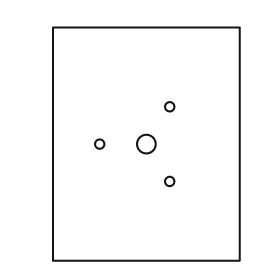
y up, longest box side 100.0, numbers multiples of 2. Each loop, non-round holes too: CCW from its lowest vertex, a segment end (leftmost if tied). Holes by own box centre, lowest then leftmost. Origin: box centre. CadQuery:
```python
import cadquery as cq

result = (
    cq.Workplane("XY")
    .moveTo(-40.0, -50.0)
    .lineTo(40.0, -50.0)
    .lineTo(40.0, 50.0)
    .lineTo(-40.0, 50.0)
    .close()
    .moveTo(10.0, -16.0)
    .circle(2.0)
    .moveTo(-20.0, 0.0)
    .circle(2.0)
    .moveTo(0.0, 0.0)
    .circle(4.0)
    .moveTo(10.0, 16.0)
    .circle(2.0)
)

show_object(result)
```